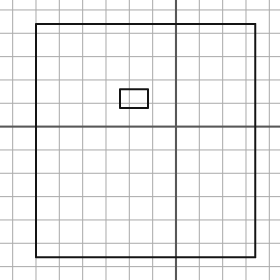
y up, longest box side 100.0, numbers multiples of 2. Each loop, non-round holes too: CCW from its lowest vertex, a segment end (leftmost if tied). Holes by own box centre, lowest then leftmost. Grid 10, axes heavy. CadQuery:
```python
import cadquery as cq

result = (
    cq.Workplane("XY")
    .moveTo(-60.0, -56.0)
    .lineTo(34.0, -56.0)
    .lineTo(34.0, 44.0)
    .lineTo(-60.0, 44.0)
    .close()
    .moveTo(-24.0, 8.0)
    .lineTo(-12.0, 8.0)
    .lineTo(-12.0, 16.0)
    .lineTo(-24.0, 16.0)
    .close()
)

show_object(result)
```